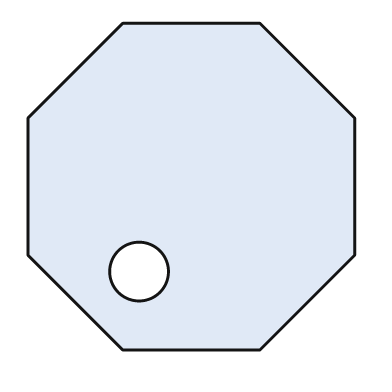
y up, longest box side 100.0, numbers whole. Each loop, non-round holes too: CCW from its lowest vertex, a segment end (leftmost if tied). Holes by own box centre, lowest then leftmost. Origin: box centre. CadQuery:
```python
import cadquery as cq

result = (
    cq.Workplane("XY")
    .moveTo(-21.0, -50.0)
    .lineTo(21.0, -50.0)
    .lineTo(50.0, -21.0)
    .lineTo(50.0, 21.0)
    .lineTo(21.0, 50.0)
    .lineTo(-21.0, 50.0)
    .lineTo(-50.0, 21.0)
    .lineTo(-50.0, -21.0)
    .close()
    .moveTo(-16.0, -26.0)
    .circle(9.0)
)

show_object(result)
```